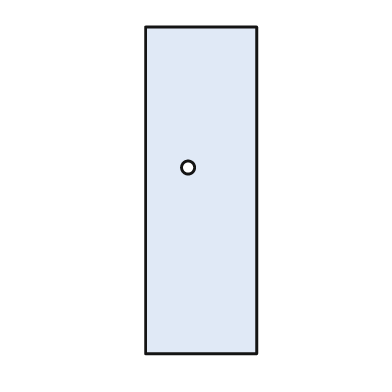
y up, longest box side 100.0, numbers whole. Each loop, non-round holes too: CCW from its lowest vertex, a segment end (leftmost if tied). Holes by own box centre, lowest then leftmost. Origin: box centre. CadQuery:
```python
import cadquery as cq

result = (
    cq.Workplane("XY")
    .moveTo(-17.0, -50.0)
    .lineTo(17.0, -50.0)
    .lineTo(17.0, 50.0)
    .lineTo(-17.0, 50.0)
    .close()
    .moveTo(-4.0, 7.0)
    .circle(2.0)
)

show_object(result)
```